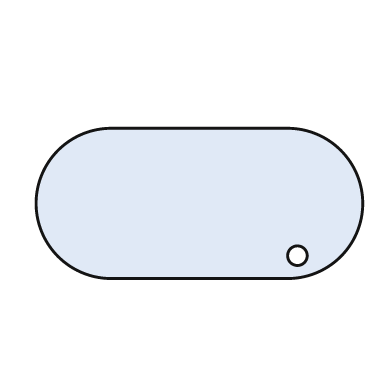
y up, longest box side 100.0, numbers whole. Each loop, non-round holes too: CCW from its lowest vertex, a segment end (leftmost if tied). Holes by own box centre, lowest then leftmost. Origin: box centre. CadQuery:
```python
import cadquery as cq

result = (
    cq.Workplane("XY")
    .moveTo(-27.0, -23.0)
    .lineTo(27.0, -23.0)
    .threePointArc((50.0, 0.0), (27.0, 23.0))
    .lineTo(-27.0, 23.0)
    .threePointArc((-50.0, 0.0), (-27.0, -23.0))
    .close()
    .moveTo(30.0, -16.0)
    .circle(3.0)
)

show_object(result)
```